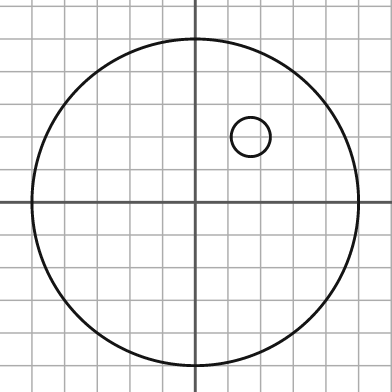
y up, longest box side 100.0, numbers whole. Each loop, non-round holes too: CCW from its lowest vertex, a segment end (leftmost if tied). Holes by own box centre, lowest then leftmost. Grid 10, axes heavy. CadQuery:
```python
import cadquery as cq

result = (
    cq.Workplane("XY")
    .moveTo(0.0, 0.0)
    .circle(50.0)
    .moveTo(17.0, 20.0)
    .circle(6.0)
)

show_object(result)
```